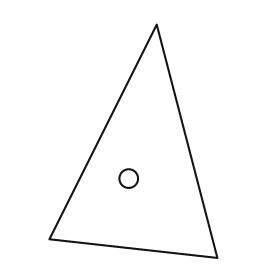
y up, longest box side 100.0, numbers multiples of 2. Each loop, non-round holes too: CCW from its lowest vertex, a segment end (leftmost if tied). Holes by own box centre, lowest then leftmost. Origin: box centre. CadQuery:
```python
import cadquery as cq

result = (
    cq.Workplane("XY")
    .moveTo(36.0, -50.0)
    .lineTo(10.0, 50.0)
    .lineTo(-36.0, -42.0)
    .close()
    .moveTo(-2.0, -16.0)
    .circle(4.0)
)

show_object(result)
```